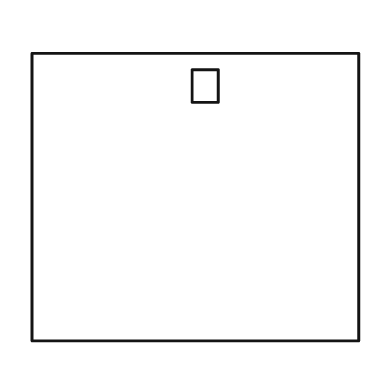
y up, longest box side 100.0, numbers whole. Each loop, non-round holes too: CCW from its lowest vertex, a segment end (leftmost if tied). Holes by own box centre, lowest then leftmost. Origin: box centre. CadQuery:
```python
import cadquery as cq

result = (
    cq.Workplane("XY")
    .moveTo(-50.0, -44.0)
    .lineTo(50.0, -44.0)
    .lineTo(50.0, 44.0)
    .lineTo(-50.0, 44.0)
    .close()
    .moveTo(-1.0, 29.0)
    .lineTo(7.0, 29.0)
    .lineTo(7.0, 39.0)
    .lineTo(-1.0, 39.0)
    .close()
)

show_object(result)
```